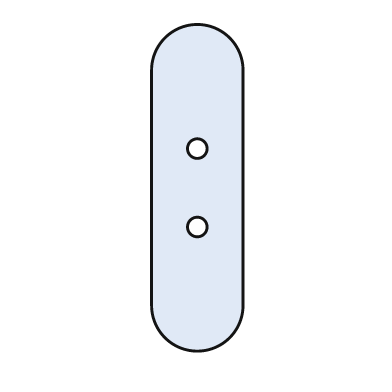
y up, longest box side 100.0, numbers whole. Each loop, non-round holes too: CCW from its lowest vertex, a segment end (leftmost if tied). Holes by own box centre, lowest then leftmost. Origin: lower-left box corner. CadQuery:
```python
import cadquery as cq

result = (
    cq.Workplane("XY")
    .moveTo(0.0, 14.0)
    .threePointArc((14.0, 0.0), (28.0, 14.0))
    .lineTo(28.0, 86.0)
    .threePointArc((14.0, 100.0), (0.0, 86.0))
    .close()
    .moveTo(14.0, 38.0)
    .circle(3.0)
    .moveTo(14.0, 62.0)
    .circle(3.0)
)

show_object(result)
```